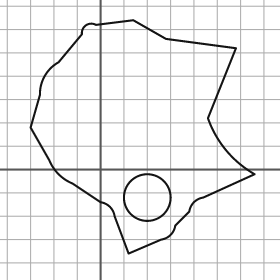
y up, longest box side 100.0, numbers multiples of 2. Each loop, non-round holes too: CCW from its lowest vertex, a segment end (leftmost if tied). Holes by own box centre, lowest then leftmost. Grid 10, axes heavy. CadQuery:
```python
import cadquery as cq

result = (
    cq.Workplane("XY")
    .moveTo(12.0, -36.0)
    .lineTo(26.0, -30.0)
    .threePointArc((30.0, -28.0), (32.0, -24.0))
    .lineTo(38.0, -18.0)
    .threePointArc((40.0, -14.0), (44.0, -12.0))
    .lineTo(66.0, -2.0)
    .threePointArc((54.0, 8.0), (46.0, 22.0))
    .lineTo(58.0, 52.0)
    .lineTo(28.0, 56.0)
    .lineTo(14.0, 64.0)
    .lineTo(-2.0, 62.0)
    .threePointArc((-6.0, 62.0), (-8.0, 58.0))
    .lineTo(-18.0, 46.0)
    .threePointArc((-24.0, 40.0), (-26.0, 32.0))
    .lineTo(-30.0, 18.0)
    .lineTo(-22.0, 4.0)
    .threePointArc((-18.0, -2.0), (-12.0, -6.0))
    .lineTo(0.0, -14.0)
    .threePointArc((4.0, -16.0), (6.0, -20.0))
    .close()
    .moveTo(20.0, -12.0)
    .circle(10.0)
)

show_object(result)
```